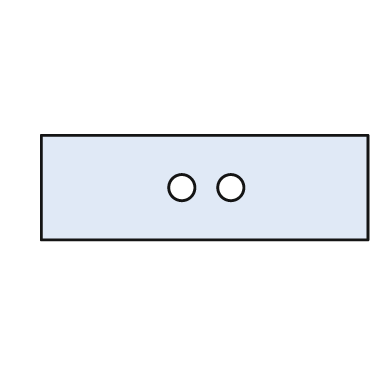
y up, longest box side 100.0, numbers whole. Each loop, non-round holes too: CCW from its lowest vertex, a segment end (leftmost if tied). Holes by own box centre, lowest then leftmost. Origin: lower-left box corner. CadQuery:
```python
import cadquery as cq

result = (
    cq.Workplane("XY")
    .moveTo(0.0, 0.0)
    .lineTo(100.0, 0.0)
    .lineTo(100.0, 32.0)
    .lineTo(0.0, 32.0)
    .close()
    .moveTo(43.0, 16.0)
    .circle(4.0)
    .moveTo(58.0, 16.0)
    .circle(4.0)
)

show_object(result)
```